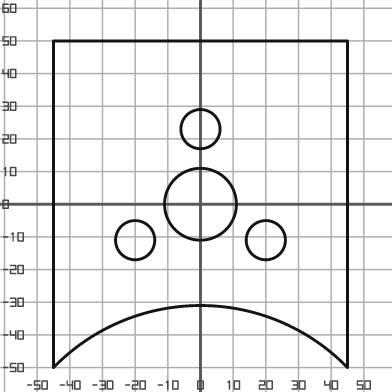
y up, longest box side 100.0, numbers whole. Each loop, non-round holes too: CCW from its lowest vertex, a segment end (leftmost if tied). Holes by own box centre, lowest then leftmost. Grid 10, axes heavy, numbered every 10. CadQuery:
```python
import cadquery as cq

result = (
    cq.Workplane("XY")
    .moveTo(-45.0, -50.0)
    .threePointArc((0.0, -31.0), (45.0, -50.0))
    .lineTo(45.0, 50.0)
    .lineTo(-45.0, 50.0)
    .close()
    .moveTo(-20.0, -11.0)
    .circle(6.0)
    .moveTo(20.0, -11.0)
    .circle(6.0)
    .moveTo(0.0, 0.0)
    .circle(11.0)
    .moveTo(0.0, 23.0)
    .circle(6.0)
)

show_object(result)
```